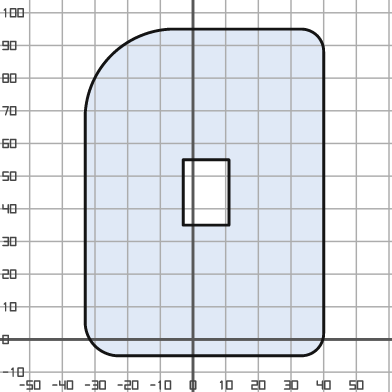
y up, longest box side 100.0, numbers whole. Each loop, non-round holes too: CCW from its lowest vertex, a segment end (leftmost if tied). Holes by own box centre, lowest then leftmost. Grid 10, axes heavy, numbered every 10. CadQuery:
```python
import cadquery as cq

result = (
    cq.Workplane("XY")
    .moveTo(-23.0, -5.0)
    .lineTo(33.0, -5.0)
    .threePointArc((38.0, -3.0), (40.0, 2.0))
    .lineTo(40.0, 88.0)
    .threePointArc((38.0, 93.0), (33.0, 95.0))
    .lineTo(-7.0, 95.0)
    .threePointArc((-25.0, 87.0), (-33.0, 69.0))
    .lineTo(-33.0, 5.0)
    .threePointArc((-30.0, -2.0), (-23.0, -5.0))
    .close()
    .moveTo(-3.0, 35.0)
    .lineTo(11.0, 35.0)
    .lineTo(11.0, 55.0)
    .lineTo(-3.0, 55.0)
    .close()
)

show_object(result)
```